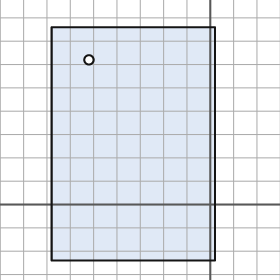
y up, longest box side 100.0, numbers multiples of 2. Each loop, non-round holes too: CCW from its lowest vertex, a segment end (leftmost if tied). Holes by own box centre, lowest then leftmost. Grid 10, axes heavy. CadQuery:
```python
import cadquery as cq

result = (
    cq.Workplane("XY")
    .moveTo(-68.0, -24.0)
    .lineTo(2.0, -24.0)
    .lineTo(2.0, 76.0)
    .lineTo(-68.0, 76.0)
    .close()
    .moveTo(-52.0, 62.0)
    .circle(2.0)
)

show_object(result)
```